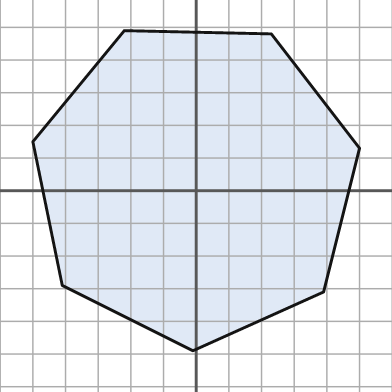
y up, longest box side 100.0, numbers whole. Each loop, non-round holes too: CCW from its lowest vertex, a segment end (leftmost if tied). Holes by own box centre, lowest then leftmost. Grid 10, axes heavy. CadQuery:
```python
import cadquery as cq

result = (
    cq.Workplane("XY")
    .moveTo(-1.0, -49.0)
    .lineTo(39.0, -31.0)
    .lineTo(50.0, 13.0)
    .lineTo(23.0, 48.0)
    .lineTo(-22.0, 49.0)
    .lineTo(-50.0, 15.0)
    .lineTo(-41.0, -29.0)
    .close()
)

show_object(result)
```